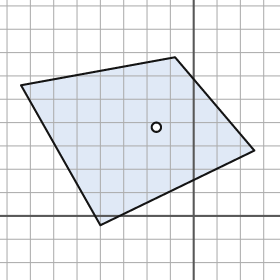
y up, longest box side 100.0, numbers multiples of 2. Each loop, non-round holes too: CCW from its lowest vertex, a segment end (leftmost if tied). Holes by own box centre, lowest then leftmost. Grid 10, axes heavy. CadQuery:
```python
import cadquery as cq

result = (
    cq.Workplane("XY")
    .moveTo(-40.0, -4.0)
    .lineTo(26.0, 28.0)
    .lineTo(-8.0, 68.0)
    .lineTo(-74.0, 56.0)
    .close()
    .moveTo(-16.0, 38.0)
    .circle(2.0)
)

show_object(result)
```